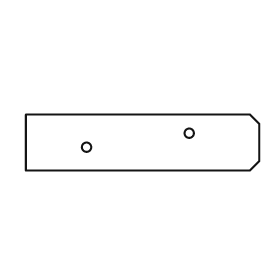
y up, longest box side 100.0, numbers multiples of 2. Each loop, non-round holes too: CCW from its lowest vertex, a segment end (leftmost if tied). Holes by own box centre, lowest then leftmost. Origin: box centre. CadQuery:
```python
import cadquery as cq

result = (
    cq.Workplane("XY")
    .moveTo(-50.0, -12.0)
    .lineTo(46.0, -12.0)
    .lineTo(50.0, -8.0)
    .lineTo(50.0, 8.0)
    .lineTo(46.0, 12.0)
    .lineTo(-50.0, 12.0)
    .close()
    .moveTo(-24.0, -2.0)
    .circle(2.0)
    .moveTo(20.0, 4.0)
    .circle(2.0)
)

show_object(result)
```